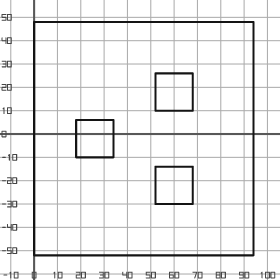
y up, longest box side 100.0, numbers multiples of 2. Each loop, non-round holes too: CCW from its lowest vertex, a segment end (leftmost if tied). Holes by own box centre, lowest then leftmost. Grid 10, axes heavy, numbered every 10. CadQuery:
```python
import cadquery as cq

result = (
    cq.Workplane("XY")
    .moveTo(0.0, -52.0)
    .lineTo(94.0, -52.0)
    .lineTo(94.0, 48.0)
    .lineTo(0.0, 48.0)
    .close()
    .moveTo(52.0, -30.0)
    .lineTo(68.0, -30.0)
    .lineTo(68.0, -14.0)
    .lineTo(52.0, -14.0)
    .close()
    .moveTo(18.0, -10.0)
    .lineTo(34.0, -10.0)
    .lineTo(34.0, 6.0)
    .lineTo(18.0, 6.0)
    .close()
    .moveTo(52.0, 10.0)
    .lineTo(68.0, 10.0)
    .lineTo(68.0, 26.0)
    .lineTo(52.0, 26.0)
    .close()
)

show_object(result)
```